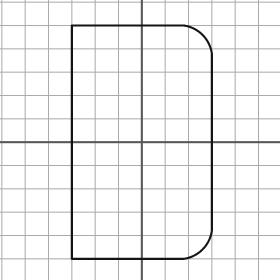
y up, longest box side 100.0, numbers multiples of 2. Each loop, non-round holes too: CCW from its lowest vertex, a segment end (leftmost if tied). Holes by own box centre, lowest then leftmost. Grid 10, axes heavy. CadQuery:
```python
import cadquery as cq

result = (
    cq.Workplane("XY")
    .moveTo(-30.0, -50.0)
    .lineTo(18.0, -50.0)
    .threePointArc((26.0, -46.0), (30.0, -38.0))
    .lineTo(30.0, 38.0)
    .threePointArc((26.0, 46.0), (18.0, 50.0))
    .lineTo(-30.0, 50.0)
    .close()
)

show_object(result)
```